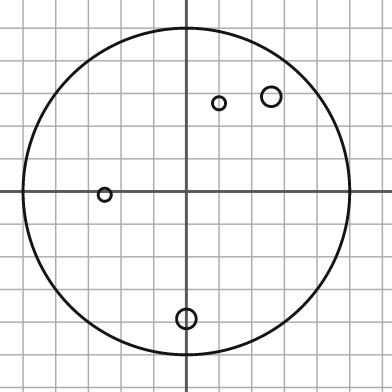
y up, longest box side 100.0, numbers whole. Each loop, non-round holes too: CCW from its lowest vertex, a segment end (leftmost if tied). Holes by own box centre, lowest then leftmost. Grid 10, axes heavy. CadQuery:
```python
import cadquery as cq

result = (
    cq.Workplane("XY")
    .moveTo(0.0, 0.0)
    .circle(50.0)
    .moveTo(0.0, -39.0)
    .circle(3.0)
    .moveTo(-25.0, -1.0)
    .circle(2.0)
    .moveTo(10.0, 27.0)
    .circle(2.0)
    .moveTo(26.0, 29.0)
    .circle(3.0)
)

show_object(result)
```